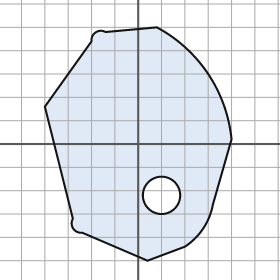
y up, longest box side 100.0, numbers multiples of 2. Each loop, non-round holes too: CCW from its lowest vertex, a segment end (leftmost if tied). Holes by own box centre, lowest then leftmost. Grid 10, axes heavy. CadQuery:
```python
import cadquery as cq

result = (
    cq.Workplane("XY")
    .moveTo(4.0, -50.0)
    .lineTo(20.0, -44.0)
    .threePointArc((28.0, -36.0), (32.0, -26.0))
    .lineTo(40.0, 2.0)
    .threePointArc((30.0, 30.0), (8.0, 50.0))
    .lineTo(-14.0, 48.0)
    .threePointArc((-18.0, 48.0), (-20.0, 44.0))
    .lineTo(-40.0, 16.0)
    .lineTo(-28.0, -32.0)
    .threePointArc((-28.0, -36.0), (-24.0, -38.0))
    .close()
    .moveTo(10.0, -22.0)
    .circle(8.0)
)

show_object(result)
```